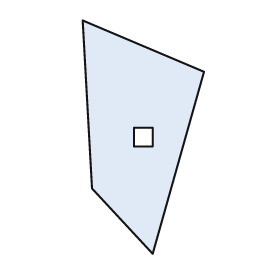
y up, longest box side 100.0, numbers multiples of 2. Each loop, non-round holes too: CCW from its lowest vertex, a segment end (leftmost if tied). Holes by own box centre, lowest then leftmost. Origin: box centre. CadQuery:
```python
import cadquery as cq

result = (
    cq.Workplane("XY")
    .moveTo(4.0, -50.0)
    .lineTo(26.0, 28.0)
    .lineTo(-26.0, 50.0)
    .lineTo(-22.0, -22.0)
    .close()
    .moveTo(-4.0, -4.0)
    .lineTo(4.0, -4.0)
    .lineTo(4.0, 4.0)
    .lineTo(-4.0, 4.0)
    .close()
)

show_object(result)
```